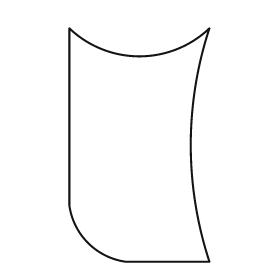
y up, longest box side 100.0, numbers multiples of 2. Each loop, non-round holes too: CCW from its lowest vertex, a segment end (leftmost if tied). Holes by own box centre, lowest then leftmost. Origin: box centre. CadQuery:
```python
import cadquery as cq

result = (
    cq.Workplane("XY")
    .moveTo(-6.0, -50.0)
    .lineTo(30.0, -50.0)
    .threePointArc((22.0, 0.0), (30.0, 50.0))
    .threePointArc((0.0, 38.0), (-30.0, 50.0))
    .lineTo(-30.0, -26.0)
    .threePointArc((-22.0, -42.0), (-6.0, -50.0))
    .close()
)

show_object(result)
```